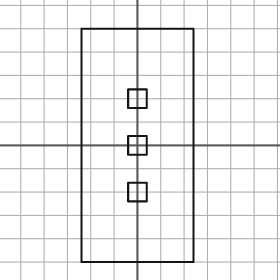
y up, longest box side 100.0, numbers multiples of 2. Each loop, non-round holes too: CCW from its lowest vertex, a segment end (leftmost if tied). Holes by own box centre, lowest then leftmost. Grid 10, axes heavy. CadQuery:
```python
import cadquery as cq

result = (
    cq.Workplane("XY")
    .moveTo(-24.0, -50.0)
    .lineTo(24.0, -50.0)
    .lineTo(24.0, 50.0)
    .lineTo(-24.0, 50.0)
    .close()
    .moveTo(-4.0, -24.0)
    .lineTo(4.0, -24.0)
    .lineTo(4.0, -16.0)
    .lineTo(-4.0, -16.0)
    .close()
    .moveTo(-4.0, -4.0)
    .lineTo(4.0, -4.0)
    .lineTo(4.0, 4.0)
    .lineTo(-4.0, 4.0)
    .close()
    .moveTo(-4.0, 16.0)
    .lineTo(4.0, 16.0)
    .lineTo(4.0, 24.0)
    .lineTo(-4.0, 24.0)
    .close()
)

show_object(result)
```